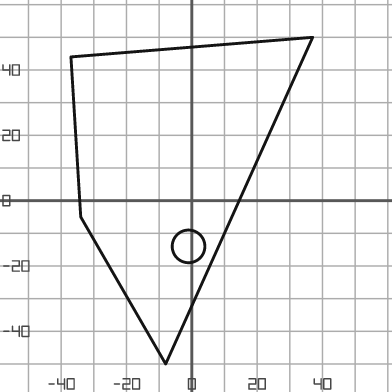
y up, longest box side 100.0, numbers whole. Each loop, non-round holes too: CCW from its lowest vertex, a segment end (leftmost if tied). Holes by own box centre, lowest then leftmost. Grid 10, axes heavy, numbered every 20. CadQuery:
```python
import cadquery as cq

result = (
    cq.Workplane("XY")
    .moveTo(-8.0, -50.0)
    .lineTo(37.0, 50.0)
    .lineTo(-37.0, 44.0)
    .lineTo(-34.0, -5.0)
    .close()
    .moveTo(-1.0, -14.0)
    .circle(5.0)
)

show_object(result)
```